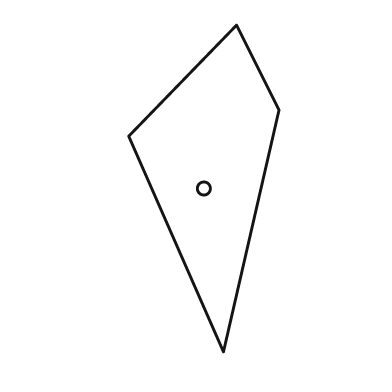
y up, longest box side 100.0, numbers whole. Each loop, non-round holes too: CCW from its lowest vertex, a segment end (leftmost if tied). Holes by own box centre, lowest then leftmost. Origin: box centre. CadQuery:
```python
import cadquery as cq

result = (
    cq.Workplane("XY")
    .moveTo(6.0, -50.0)
    .lineTo(23.0, 24.0)
    .lineTo(10.0, 50.0)
    .lineTo(-23.0, 16.0)
    .close()
    .moveTo(0.0, 0.0)
    .circle(2.0)
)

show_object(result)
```